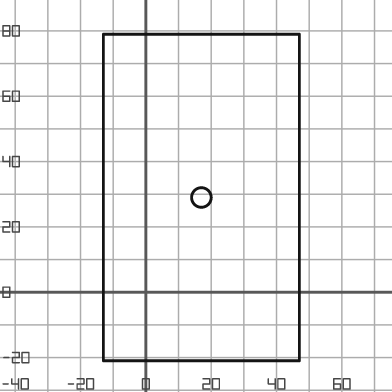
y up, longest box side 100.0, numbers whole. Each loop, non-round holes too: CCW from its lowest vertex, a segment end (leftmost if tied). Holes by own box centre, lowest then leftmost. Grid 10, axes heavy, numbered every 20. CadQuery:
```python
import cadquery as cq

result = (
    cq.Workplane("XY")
    .moveTo(-13.0, -21.0)
    .lineTo(47.0, -21.0)
    .lineTo(47.0, 79.0)
    .lineTo(-13.0, 79.0)
    .close()
    .moveTo(17.0, 29.0)
    .circle(3.0)
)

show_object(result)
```